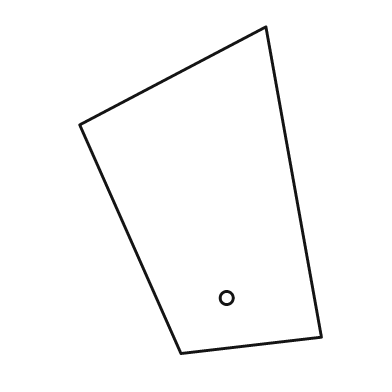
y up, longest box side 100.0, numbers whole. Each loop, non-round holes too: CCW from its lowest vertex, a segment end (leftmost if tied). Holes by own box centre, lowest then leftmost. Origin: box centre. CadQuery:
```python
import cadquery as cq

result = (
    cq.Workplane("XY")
    .moveTo(-6.0, -50.0)
    .lineTo(37.0, -45.0)
    .lineTo(20.0, 50.0)
    .lineTo(-37.0, 20.0)
    .close()
    .moveTo(8.0, -33.0)
    .circle(2.0)
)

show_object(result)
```